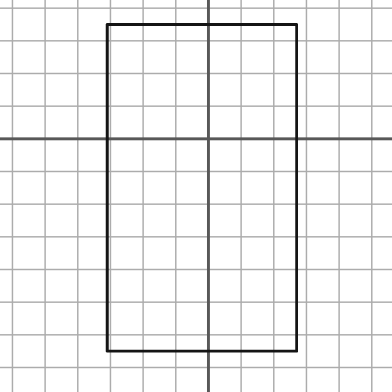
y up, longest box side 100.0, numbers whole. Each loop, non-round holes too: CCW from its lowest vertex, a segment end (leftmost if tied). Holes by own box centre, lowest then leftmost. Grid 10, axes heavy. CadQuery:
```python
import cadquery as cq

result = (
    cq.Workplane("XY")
    .moveTo(-31.0, -65.0)
    .lineTo(27.0, -65.0)
    .lineTo(27.0, 35.0)
    .lineTo(-31.0, 35.0)
    .close()
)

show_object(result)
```